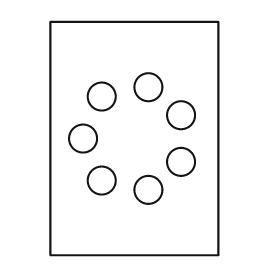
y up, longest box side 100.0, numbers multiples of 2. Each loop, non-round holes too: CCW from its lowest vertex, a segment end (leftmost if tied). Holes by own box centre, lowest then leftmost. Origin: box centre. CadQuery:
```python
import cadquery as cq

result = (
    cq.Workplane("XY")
    .moveTo(-36.0, -50.0)
    .lineTo(36.0, -50.0)
    .lineTo(36.0, 50.0)
    .lineTo(-36.0, 50.0)
    .close()
    .moveTo(6.0, -22.0)
    .circle(6.0)
    .moveTo(-14.0, -18.0)
    .circle(6.0)
    .moveTo(20.0, -10.0)
    .circle(6.0)
    .moveTo(-22.0, 0.0)
    .circle(6.0)
    .moveTo(20.0, 10.0)
    .circle(6.0)
    .moveTo(-14.0, 18.0)
    .circle(6.0)
    .moveTo(6.0, 22.0)
    .circle(6.0)
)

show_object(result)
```